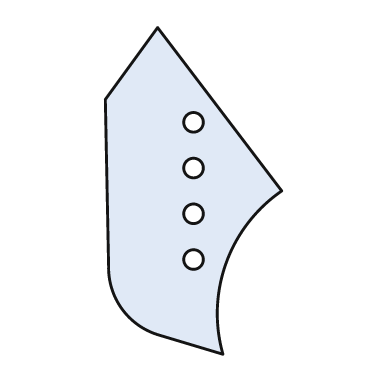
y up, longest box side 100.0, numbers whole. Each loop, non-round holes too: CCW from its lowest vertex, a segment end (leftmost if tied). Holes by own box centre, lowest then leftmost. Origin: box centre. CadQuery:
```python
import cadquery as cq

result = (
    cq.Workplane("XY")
    .moveTo(9.0, -50.0)
    .threePointArc((10.0, -22.0), (27.0, 0.0))
    .lineTo(-11.0, 50.0)
    .lineTo(-27.0, 28.0)
    .lineTo(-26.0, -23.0)
    .threePointArc((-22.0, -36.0), (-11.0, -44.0))
    .close()
    .moveTo(0.0, -21.0)
    .circle(3.0)
    .moveTo(0.0, -7.0)
    .circle(3.0)
    .moveTo(0.0, 7.0)
    .circle(3.0)
    .moveTo(0.0, 21.0)
    .circle(3.0)
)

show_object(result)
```